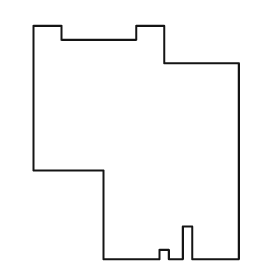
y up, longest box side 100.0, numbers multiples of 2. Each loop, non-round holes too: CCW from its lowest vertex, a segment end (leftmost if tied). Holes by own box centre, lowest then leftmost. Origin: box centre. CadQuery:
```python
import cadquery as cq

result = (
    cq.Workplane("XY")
    .moveTo(-14.0, -50.0)
    .lineTo(10.0, -50.0)
    .lineTo(10.0, -46.0)
    .lineTo(14.0, -46.0)
    .lineTo(14.0, -50.0)
    .lineTo(20.0, -50.0)
    .lineTo(20.0, -36.0)
    .lineTo(24.0, -36.0)
    .lineTo(24.0, -50.0)
    .lineTo(44.0, -50.0)
    .lineTo(44.0, 34.0)
    .lineTo(12.0, 34.0)
    .lineTo(12.0, 50.0)
    .lineTo(0.0, 50.0)
    .lineTo(0.0, 44.0)
    .lineTo(-32.0, 44.0)
    .lineTo(-32.0, 50.0)
    .lineTo(-44.0, 50.0)
    .lineTo(-44.0, -12.0)
    .lineTo(-14.0, -12.0)
    .close()
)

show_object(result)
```